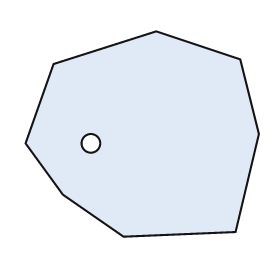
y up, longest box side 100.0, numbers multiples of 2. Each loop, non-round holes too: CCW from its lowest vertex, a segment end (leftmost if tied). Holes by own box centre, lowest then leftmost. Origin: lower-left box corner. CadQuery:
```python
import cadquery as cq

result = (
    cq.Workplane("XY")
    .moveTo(42.0, 0.0)
    .lineTo(90.0, 2.0)
    .lineTo(100.0, 44.0)
    .lineTo(92.0, 76.0)
    .lineTo(56.0, 88.0)
    .lineTo(12.0, 74.0)
    .lineTo(0.0, 40.0)
    .lineTo(16.0, 18.0)
    .close()
    .moveTo(28.0, 40.0)
    .circle(4.0)
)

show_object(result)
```